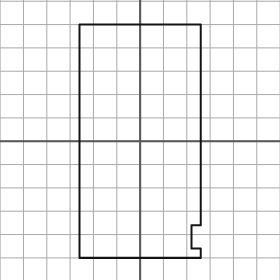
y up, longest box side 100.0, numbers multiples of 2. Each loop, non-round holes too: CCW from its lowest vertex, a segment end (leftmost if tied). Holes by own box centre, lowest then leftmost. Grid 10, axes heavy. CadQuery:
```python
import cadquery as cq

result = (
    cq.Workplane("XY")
    .moveTo(-26.0, -50.0)
    .lineTo(26.0, -50.0)
    .lineTo(26.0, -46.0)
    .lineTo(22.0, -46.0)
    .lineTo(22.0, -36.0)
    .lineTo(26.0, -36.0)
    .lineTo(26.0, 50.0)
    .lineTo(-26.0, 50.0)
    .close()
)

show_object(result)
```